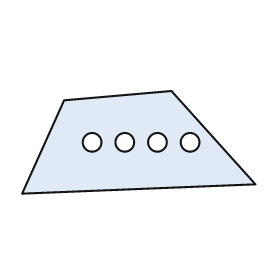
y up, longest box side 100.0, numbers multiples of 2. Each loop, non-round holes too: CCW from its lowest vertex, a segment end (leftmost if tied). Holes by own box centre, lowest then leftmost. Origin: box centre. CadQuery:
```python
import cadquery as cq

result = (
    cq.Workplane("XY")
    .moveTo(-50.0, -22.0)
    .lineTo(50.0, -18.0)
    .lineTo(14.0, 22.0)
    .lineTo(-32.0, 18.0)
    .close()
    .moveTo(-20.0, 0.0)
    .circle(4.0)
    .moveTo(-6.0, 0.0)
    .circle(4.0)
    .moveTo(8.0, 0.0)
    .circle(4.0)
    .moveTo(22.0, 0.0)
    .circle(4.0)
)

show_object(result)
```